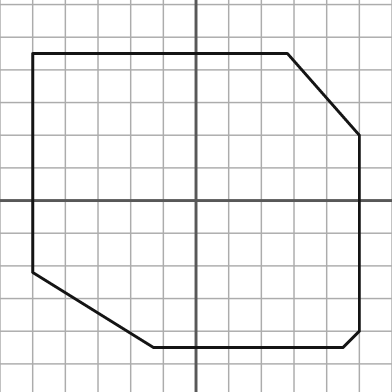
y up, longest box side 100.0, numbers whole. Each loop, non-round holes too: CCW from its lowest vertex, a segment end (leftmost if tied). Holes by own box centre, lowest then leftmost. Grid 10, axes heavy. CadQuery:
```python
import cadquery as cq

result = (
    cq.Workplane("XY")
    .moveTo(-13.0, -45.0)
    .lineTo(45.0, -45.0)
    .lineTo(50.0, -40.0)
    .lineTo(50.0, 20.0)
    .lineTo(28.0, 45.0)
    .lineTo(-50.0, 45.0)
    .lineTo(-50.0, -22.0)
    .close()
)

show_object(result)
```